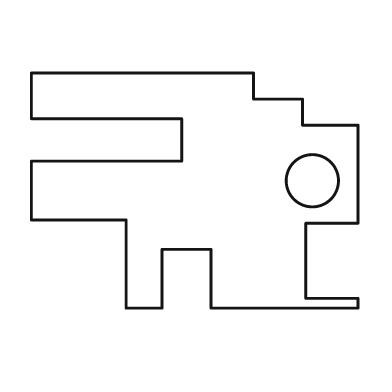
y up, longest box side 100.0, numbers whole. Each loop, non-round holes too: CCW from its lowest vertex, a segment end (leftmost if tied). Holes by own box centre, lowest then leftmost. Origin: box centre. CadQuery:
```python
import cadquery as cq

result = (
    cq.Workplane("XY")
    .moveTo(-21.0, -36.0)
    .lineTo(-10.0, -36.0)
    .lineTo(-10.0, -18.0)
    .lineTo(5.0, -18.0)
    .lineTo(5.0, -36.0)
    .lineTo(50.0, -36.0)
    .lineTo(50.0, -33.0)
    .lineTo(34.0, -33.0)
    .lineTo(34.0, -10.0)
    .lineTo(50.0, -10.0)
    .lineTo(50.0, 20.0)
    .lineTo(33.0, 20.0)
    .lineTo(33.0, 28.0)
    .lineTo(18.0, 28.0)
    .lineTo(18.0, 36.0)
    .lineTo(-50.0, 36.0)
    .lineTo(-50.0, 22.0)
    .lineTo(-4.0, 22.0)
    .lineTo(-4.0, 9.0)
    .lineTo(-50.0, 9.0)
    .lineTo(-50.0, -9.0)
    .lineTo(-21.0, -9.0)
    .close()
    .moveTo(36.0, 3.0)
    .circle(8.0)
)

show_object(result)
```